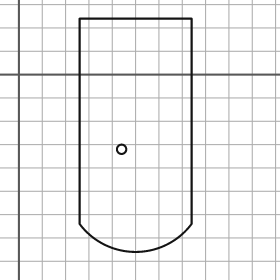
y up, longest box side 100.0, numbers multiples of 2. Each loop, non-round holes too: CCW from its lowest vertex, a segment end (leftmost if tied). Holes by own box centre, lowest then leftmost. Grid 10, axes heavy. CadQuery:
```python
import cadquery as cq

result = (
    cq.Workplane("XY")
    .moveTo(26.0, -64.0)
    .threePointArc((50.0, -76.0), (74.0, -64.0))
    .lineTo(74.0, 24.0)
    .lineTo(26.0, 24.0)
    .close()
    .moveTo(44.0, -32.0)
    .circle(2.0)
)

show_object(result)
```